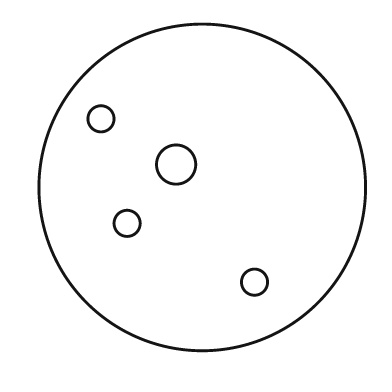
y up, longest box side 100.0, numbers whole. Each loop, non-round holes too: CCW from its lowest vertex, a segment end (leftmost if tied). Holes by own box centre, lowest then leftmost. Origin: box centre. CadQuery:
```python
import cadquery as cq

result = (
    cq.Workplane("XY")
    .moveTo(0.0, 0.0)
    .circle(50.0)
    .moveTo(16.0, -29.0)
    .circle(4.0)
    .moveTo(-23.0, -11.0)
    .circle(4.0)
    .moveTo(-8.0, 7.0)
    .circle(6.0)
    .moveTo(-31.0, 21.0)
    .circle(4.0)
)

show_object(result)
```